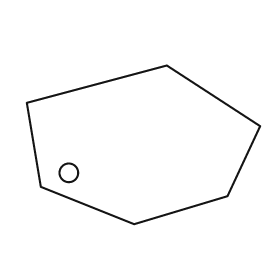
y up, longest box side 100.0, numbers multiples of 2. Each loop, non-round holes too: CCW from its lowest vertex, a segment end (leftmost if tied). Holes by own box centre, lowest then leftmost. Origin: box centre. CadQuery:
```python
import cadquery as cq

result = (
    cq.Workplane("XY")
    .moveTo(-4.0, -34.0)
    .lineTo(36.0, -22.0)
    .lineTo(50.0, 8.0)
    .lineTo(10.0, 34.0)
    .lineTo(-50.0, 18.0)
    .lineTo(-44.0, -18.0)
    .close()
    .moveTo(-32.0, -12.0)
    .circle(4.0)
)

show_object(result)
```